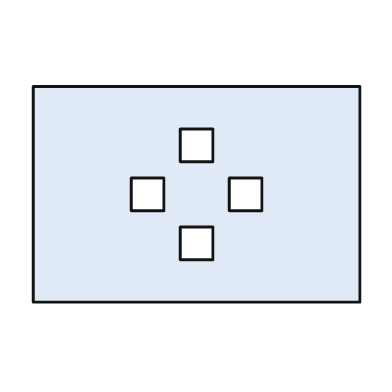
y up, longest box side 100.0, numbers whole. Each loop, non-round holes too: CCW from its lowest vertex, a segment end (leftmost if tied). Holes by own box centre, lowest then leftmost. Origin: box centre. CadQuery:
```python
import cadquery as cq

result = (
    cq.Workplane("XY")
    .moveTo(-50.0, -33.0)
    .lineTo(50.0, -33.0)
    .lineTo(50.0, 33.0)
    .lineTo(-50.0, 33.0)
    .close()
    .moveTo(-5.0, -20.0)
    .lineTo(5.0, -20.0)
    .lineTo(5.0, -10.0)
    .lineTo(-5.0, -10.0)
    .close()
    .moveTo(-20.0, -5.0)
    .lineTo(-10.0, -5.0)
    .lineTo(-10.0, 5.0)
    .lineTo(-20.0, 5.0)
    .close()
    .moveTo(10.0, -5.0)
    .lineTo(20.0, -5.0)
    .lineTo(20.0, 5.0)
    .lineTo(10.0, 5.0)
    .close()
    .moveTo(-5.0, 10.0)
    .lineTo(5.0, 10.0)
    .lineTo(5.0, 20.0)
    .lineTo(-5.0, 20.0)
    .close()
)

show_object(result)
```